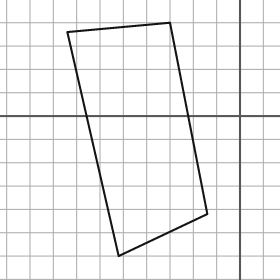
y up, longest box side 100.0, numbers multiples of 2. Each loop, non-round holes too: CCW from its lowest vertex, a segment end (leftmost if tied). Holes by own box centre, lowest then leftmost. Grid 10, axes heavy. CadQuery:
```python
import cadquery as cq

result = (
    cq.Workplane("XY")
    .moveTo(-52.0, -60.0)
    .lineTo(-14.0, -42.0)
    .lineTo(-30.0, 40.0)
    .lineTo(-74.0, 36.0)
    .close()
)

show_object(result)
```